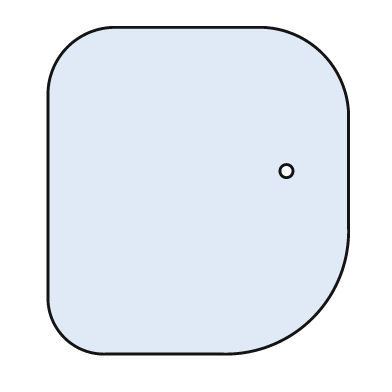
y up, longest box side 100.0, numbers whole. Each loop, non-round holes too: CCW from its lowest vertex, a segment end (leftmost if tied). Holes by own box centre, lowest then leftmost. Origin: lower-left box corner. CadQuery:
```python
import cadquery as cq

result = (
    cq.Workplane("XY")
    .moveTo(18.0, 0.0)
    .lineTo(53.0, 0.0)
    .threePointArc((81.0, 11.0), (92.0, 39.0))
    .lineTo(92.0, 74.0)
    .threePointArc((84.0, 92.0), (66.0, 100.0))
    .lineTo(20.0, 100.0)
    .threePointArc((6.0, 94.0), (0.0, 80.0))
    .lineTo(0.0, 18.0)
    .threePointArc((5.0, 5.0), (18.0, 0.0))
    .close()
    .moveTo(73.0, 56.0)
    .circle(2.0)
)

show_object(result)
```